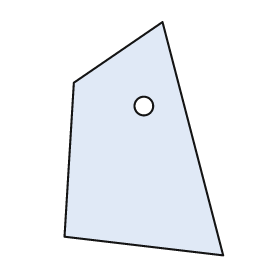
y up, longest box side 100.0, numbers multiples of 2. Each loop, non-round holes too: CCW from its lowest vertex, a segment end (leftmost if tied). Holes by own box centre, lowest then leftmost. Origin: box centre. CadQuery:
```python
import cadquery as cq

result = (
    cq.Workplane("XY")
    .moveTo(34.0, -50.0)
    .lineTo(8.0, 50.0)
    .lineTo(-30.0, 24.0)
    .lineTo(-34.0, -42.0)
    .close()
    .moveTo(0.0, 14.0)
    .circle(4.0)
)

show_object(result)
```